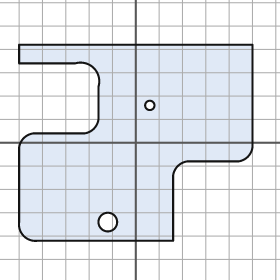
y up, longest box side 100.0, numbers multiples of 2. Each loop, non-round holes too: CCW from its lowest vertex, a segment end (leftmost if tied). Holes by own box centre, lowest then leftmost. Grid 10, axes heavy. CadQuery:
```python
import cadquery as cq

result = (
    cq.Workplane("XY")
    .moveTo(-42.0, -42.0)
    .lineTo(16.0, -42.0)
    .lineTo(16.0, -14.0)
    .threePointArc((18.0, -10.0), (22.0, -8.0))
    .lineTo(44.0, -8.0)
    .threePointArc((48.0, -6.0), (50.0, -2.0))
    .lineTo(50.0, 42.0)
    .lineTo(-50.0, 42.0)
    .lineTo(-50.0, 34.0)
    .lineTo(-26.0, 34.0)
    .threePointArc((-18.0, 32.0), (-16.0, 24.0))
    .lineTo(-16.0, 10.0)
    .threePointArc((-18.0, 6.0), (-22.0, 4.0))
    .lineTo(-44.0, 4.0)
    .threePointArc((-48.0, 2.0), (-50.0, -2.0))
    .lineTo(-50.0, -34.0)
    .threePointArc((-48.0, -40.0), (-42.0, -42.0))
    .close()
    .moveTo(-12.0, -34.0)
    .circle(4.0)
    .moveTo(6.0, 16.0)
    .circle(2.0)
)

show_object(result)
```